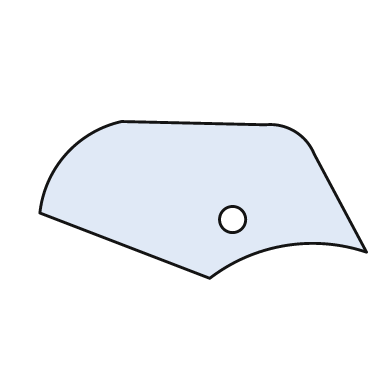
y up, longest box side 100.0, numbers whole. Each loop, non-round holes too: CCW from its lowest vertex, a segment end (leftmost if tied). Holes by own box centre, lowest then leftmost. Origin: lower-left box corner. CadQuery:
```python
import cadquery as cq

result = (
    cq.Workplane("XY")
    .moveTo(52.0, 0.0)
    .threePointArc((75.0, 10.0), (100.0, 8.0))
    .lineTo(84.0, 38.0)
    .threePointArc((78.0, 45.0), (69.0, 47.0))
    .lineTo(25.0, 48.0)
    .threePointArc((8.0, 38.0), (0.0, 20.0))
    .close()
    .moveTo(59.0, 18.0)
    .circle(4.0)
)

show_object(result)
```